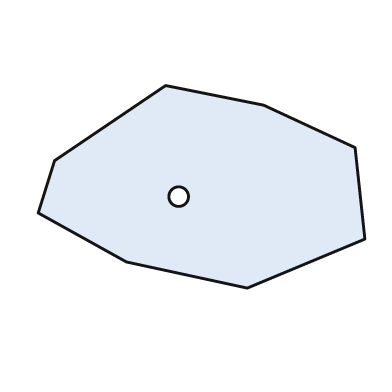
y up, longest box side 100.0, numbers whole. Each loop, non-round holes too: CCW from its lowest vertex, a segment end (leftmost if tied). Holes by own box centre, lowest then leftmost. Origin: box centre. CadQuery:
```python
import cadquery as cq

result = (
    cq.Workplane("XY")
    .moveTo(14.0, -31.0)
    .lineTo(50.0, -16.0)
    .lineTo(47.0, 12.0)
    .lineTo(19.0, 25.0)
    .lineTo(-11.0, 31.0)
    .lineTo(-45.0, 8.0)
    .lineTo(-50.0, -8.0)
    .lineTo(-23.0, -23.0)
    .close()
    .moveTo(-7.0, -3.0)
    .circle(3.0)
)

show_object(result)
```